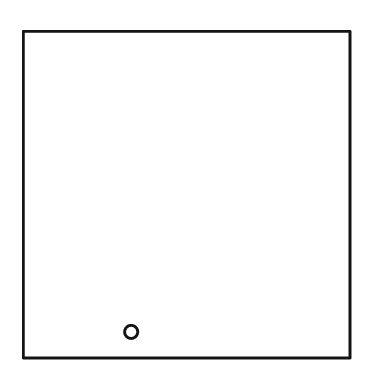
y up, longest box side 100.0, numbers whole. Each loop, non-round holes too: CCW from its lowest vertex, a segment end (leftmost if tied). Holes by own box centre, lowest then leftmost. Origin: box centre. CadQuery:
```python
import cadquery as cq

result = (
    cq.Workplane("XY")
    .moveTo(-50.0, -50.0)
    .lineTo(50.0, -50.0)
    .lineTo(50.0, 50.0)
    .lineTo(-50.0, 50.0)
    .close()
    .moveTo(-17.0, -42.0)
    .circle(2.0)
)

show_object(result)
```